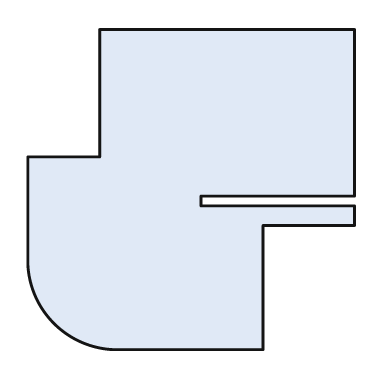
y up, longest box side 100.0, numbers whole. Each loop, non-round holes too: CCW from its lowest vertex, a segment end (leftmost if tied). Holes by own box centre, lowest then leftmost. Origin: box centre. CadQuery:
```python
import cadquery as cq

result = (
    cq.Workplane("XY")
    .moveTo(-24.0, -49.0)
    .lineTo(22.0, -49.0)
    .lineTo(22.0, -11.0)
    .lineTo(50.0, -11.0)
    .lineTo(50.0, -5.0)
    .lineTo(3.0, -5.0)
    .lineTo(3.0, -2.0)
    .lineTo(50.0, -2.0)
    .lineTo(50.0, 49.0)
    .lineTo(-28.0, 49.0)
    .lineTo(-28.0, 10.0)
    .lineTo(-50.0, 10.0)
    .lineTo(-50.0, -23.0)
    .threePointArc((-42.0, -41.0), (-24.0, -49.0))
    .close()
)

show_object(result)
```